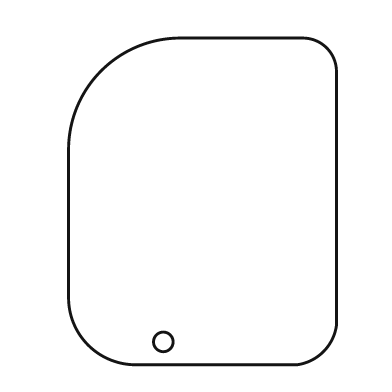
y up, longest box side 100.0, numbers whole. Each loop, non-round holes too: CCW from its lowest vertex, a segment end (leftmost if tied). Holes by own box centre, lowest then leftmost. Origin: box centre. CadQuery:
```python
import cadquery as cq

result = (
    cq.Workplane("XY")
    .moveTo(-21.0, -50.0)
    .lineTo(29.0, -50.0)
    .threePointArc((37.0, -46.0), (41.0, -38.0))
    .lineTo(41.0, 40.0)
    .threePointArc((38.0, 47.0), (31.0, 50.0))
    .lineTo(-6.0, 50.0)
    .threePointArc((-31.0, 40.0), (-41.0, 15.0))
    .lineTo(-41.0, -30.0)
    .threePointArc((-35.0, -44.0), (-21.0, -50.0))
    .close()
    .moveTo(-12.0, -43.0)
    .circle(3.0)
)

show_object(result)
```